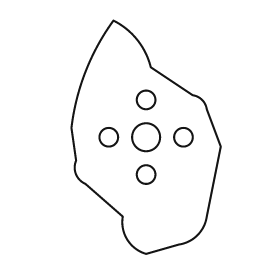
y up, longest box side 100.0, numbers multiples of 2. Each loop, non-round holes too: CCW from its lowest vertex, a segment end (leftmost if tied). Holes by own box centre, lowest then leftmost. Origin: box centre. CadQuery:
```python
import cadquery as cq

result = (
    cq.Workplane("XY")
    .moveTo(0.0, -50.0)
    .lineTo(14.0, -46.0)
    .threePointArc((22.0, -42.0), (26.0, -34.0))
    .lineTo(32.0, -4.0)
    .lineTo(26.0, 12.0)
    .threePointArc((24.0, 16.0), (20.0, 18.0))
    .lineTo(2.0, 30.0)
    .threePointArc((-4.0, 42.0), (-14.0, 50.0))
    .threePointArc((-26.0, 28.0), (-32.0, 4.0))
    .lineTo(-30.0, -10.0)
    .threePointArc((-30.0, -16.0), (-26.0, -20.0))
    .lineTo(-10.0, -34.0)
    .threePointArc((-8.0, -44.0), (0.0, -50.0))
    .close()
    .moveTo(0.0, -16.0)
    .circle(4.0)
    .moveTo(-16.0, 0.0)
    .circle(4.0)
    .moveTo(0.0, 0.0)
    .circle(6.0)
    .moveTo(16.0, 0.0)
    .circle(4.0)
    .moveTo(0.0, 16.0)
    .circle(4.0)
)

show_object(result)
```